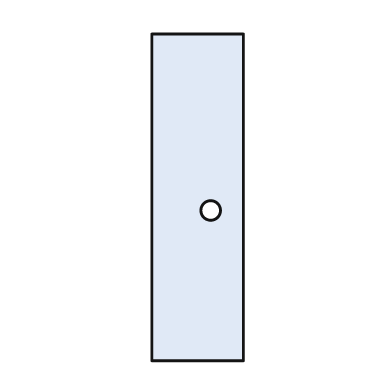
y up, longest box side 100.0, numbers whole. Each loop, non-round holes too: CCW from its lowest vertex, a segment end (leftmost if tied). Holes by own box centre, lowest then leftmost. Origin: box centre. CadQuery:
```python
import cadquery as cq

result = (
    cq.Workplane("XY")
    .moveTo(-14.0, -50.0)
    .lineTo(14.0, -50.0)
    .lineTo(14.0, 50.0)
    .lineTo(-14.0, 50.0)
    .close()
    .moveTo(4.0, -4.0)
    .circle(3.0)
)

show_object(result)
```